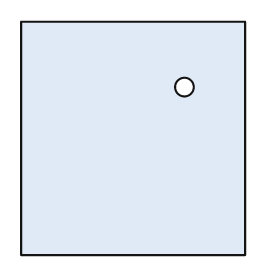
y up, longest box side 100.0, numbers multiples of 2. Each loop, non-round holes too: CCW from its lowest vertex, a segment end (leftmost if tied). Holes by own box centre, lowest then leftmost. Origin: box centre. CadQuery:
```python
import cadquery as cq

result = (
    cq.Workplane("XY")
    .moveTo(-48.0, -50.0)
    .lineTo(48.0, -50.0)
    .lineTo(48.0, 50.0)
    .lineTo(-48.0, 50.0)
    .close()
    .moveTo(22.0, 22.0)
    .circle(4.0)
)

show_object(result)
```